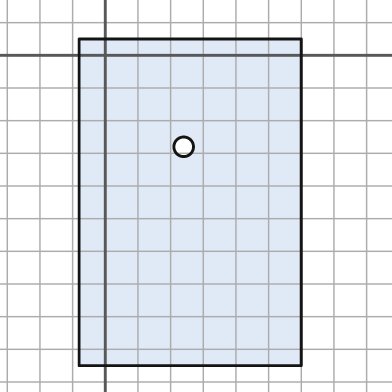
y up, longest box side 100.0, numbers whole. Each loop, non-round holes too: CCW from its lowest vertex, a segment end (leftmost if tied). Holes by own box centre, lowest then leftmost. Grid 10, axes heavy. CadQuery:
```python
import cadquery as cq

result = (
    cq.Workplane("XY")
    .moveTo(-8.0, -95.0)
    .lineTo(60.0, -95.0)
    .lineTo(60.0, 5.0)
    .lineTo(-8.0, 5.0)
    .close()
    .moveTo(24.0, -28.0)
    .circle(3.0)
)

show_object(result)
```